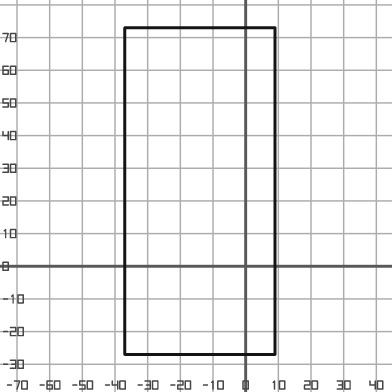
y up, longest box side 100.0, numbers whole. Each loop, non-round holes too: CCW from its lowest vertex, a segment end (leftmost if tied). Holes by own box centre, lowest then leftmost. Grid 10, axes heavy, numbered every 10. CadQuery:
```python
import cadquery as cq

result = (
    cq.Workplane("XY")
    .moveTo(-37.0, -27.0)
    .lineTo(9.0, -27.0)
    .lineTo(9.0, 73.0)
    .lineTo(-37.0, 73.0)
    .close()
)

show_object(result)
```